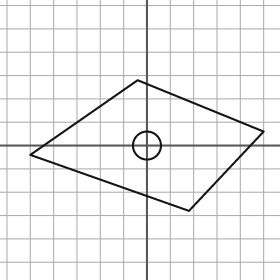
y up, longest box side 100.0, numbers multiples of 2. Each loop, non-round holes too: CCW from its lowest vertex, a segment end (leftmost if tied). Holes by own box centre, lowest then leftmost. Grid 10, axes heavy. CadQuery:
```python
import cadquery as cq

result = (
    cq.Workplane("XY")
    .moveTo(18.0, -28.0)
    .lineTo(50.0, 6.0)
    .lineTo(-4.0, 28.0)
    .lineTo(-50.0, -4.0)
    .close()
    .moveTo(0.0, 0.0)
    .circle(6.0)
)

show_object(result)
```